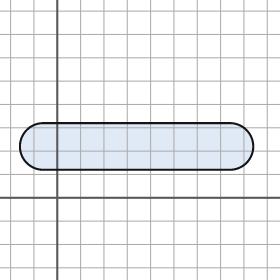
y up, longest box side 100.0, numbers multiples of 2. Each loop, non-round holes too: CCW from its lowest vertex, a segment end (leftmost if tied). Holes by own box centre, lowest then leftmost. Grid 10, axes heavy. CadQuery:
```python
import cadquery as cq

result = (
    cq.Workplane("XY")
    .moveTo(-6.0, 12.0)
    .lineTo(74.0, 12.0)
    .threePointArc((84.0, 22.0), (74.0, 32.0))
    .lineTo(-6.0, 32.0)
    .threePointArc((-16.0, 22.0), (-6.0, 12.0))
    .close()
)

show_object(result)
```